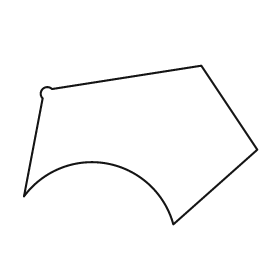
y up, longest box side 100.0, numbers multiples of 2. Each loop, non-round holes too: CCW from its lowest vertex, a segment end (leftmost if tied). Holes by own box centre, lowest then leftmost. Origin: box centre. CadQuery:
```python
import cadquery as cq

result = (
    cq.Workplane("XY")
    .moveTo(14.0, -34.0)
    .lineTo(50.0, -2.0)
    .lineTo(26.0, 34.0)
    .lineTo(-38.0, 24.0)
    .threePointArc((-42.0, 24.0), (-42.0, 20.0))
    .lineTo(-50.0, -22.0)
    .threePointArc((-14.0, -8.0), (14.0, -34.0))
    .close()
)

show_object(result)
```